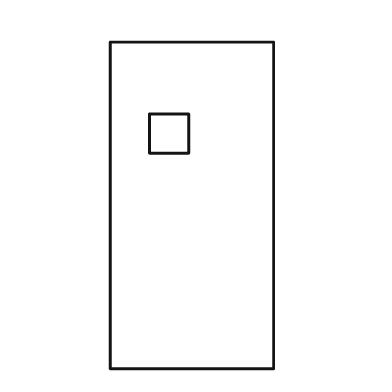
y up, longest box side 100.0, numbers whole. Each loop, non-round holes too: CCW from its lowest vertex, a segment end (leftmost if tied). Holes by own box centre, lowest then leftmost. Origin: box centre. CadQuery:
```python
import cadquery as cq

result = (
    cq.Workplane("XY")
    .moveTo(-25.0, -50.0)
    .lineTo(25.0, -50.0)
    .lineTo(25.0, 50.0)
    .lineTo(-25.0, 50.0)
    .close()
    .moveTo(-13.0, 16.0)
    .lineTo(-1.0, 16.0)
    .lineTo(-1.0, 28.0)
    .lineTo(-13.0, 28.0)
    .close()
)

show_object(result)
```